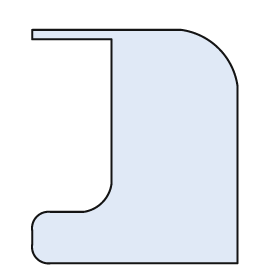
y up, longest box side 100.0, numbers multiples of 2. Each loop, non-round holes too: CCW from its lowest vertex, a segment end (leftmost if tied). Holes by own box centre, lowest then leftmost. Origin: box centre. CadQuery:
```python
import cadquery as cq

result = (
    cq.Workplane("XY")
    .moveTo(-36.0, -50.0)
    .lineTo(44.0, -50.0)
    .lineTo(44.0, 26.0)
    .threePointArc((36.0, 42.0), (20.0, 50.0))
    .lineTo(-44.0, 50.0)
    .lineTo(-44.0, 46.0)
    .lineTo(-10.0, 46.0)
    .lineTo(-10.0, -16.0)
    .threePointArc((-14.0, -24.0), (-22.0, -28.0))
    .lineTo(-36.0, -28.0)
    .threePointArc((-42.0, -30.0), (-44.0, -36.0))
    .lineTo(-44.0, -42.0)
    .threePointArc((-42.0, -48.0), (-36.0, -50.0))
    .close()
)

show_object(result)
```